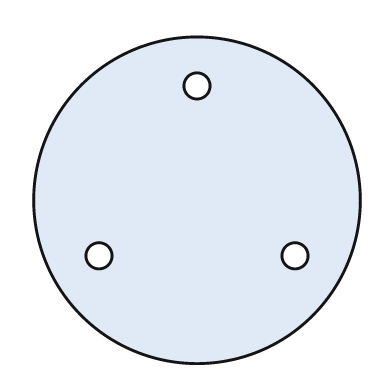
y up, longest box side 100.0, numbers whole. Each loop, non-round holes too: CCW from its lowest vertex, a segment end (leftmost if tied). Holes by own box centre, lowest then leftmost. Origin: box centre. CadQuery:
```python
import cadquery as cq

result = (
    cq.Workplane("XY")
    .moveTo(0.0, 0.0)
    .circle(50.0)
    .moveTo(-30.0, -17.0)
    .circle(4.0)
    .moveTo(30.0, -17.0)
    .circle(4.0)
    .moveTo(0.0, 35.0)
    .circle(4.0)
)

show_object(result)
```